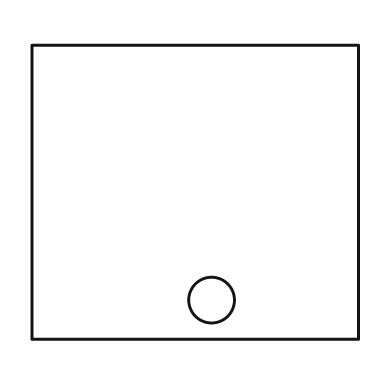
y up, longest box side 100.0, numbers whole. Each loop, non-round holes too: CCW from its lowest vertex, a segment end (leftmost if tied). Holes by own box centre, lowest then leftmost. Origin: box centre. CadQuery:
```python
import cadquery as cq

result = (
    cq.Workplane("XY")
    .moveTo(-50.0, -45.0)
    .lineTo(50.0, -45.0)
    .lineTo(50.0, 45.0)
    .lineTo(-50.0, 45.0)
    .close()
    .moveTo(5.0, -33.0)
    .circle(7.0)
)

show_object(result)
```